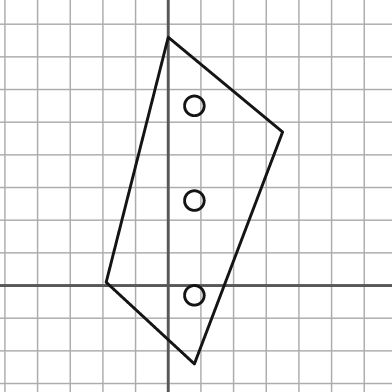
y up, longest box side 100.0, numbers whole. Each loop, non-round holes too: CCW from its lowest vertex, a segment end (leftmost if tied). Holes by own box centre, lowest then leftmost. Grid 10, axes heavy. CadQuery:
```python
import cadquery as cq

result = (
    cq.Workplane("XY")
    .moveTo(8.0, -24.0)
    .lineTo(35.0, 47.0)
    .lineTo(0.0, 76.0)
    .lineTo(-19.0, 1.0)
    .close()
    .moveTo(8.0, -3.0)
    .circle(3.0)
    .moveTo(8.0, 26.0)
    .circle(3.0)
    .moveTo(8.0, 55.0)
    .circle(3.0)
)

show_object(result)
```